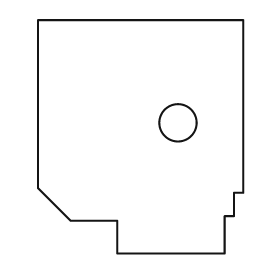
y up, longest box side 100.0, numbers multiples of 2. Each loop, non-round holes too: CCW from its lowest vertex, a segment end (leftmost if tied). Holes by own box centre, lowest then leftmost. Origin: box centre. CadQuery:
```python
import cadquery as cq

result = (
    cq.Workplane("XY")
    .moveTo(-10.0, -50.0)
    .lineTo(36.0, -50.0)
    .lineTo(36.0, -34.0)
    .lineTo(40.0, -34.0)
    .lineTo(40.0, -24.0)
    .lineTo(44.0, -24.0)
    .lineTo(44.0, 50.0)
    .lineTo(-44.0, 50.0)
    .lineTo(-44.0, -22.0)
    .lineTo(-30.0, -36.0)
    .lineTo(-10.0, -36.0)
    .close()
    .moveTo(16.0, 6.0)
    .circle(8.0)
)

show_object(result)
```